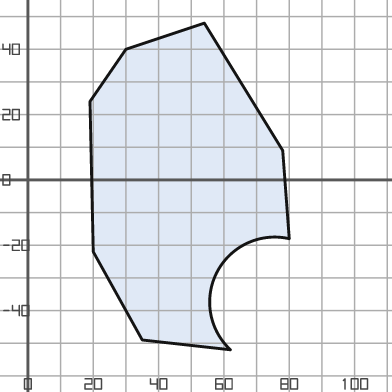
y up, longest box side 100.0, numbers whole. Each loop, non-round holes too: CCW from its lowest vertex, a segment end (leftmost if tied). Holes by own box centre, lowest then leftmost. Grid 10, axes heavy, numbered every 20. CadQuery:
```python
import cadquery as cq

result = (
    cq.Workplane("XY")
    .moveTo(62.0, -52.0)
    .threePointArc((58.0, -28.0), (80.0, -18.0))
    .lineTo(78.0, 9.0)
    .lineTo(54.0, 48.0)
    .lineTo(30.0, 40.0)
    .lineTo(19.0, 24.0)
    .lineTo(20.0, -22.0)
    .lineTo(35.0, -49.0)
    .close()
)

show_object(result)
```